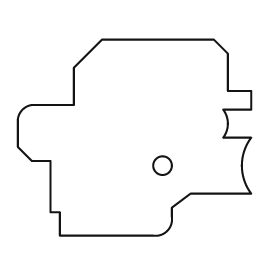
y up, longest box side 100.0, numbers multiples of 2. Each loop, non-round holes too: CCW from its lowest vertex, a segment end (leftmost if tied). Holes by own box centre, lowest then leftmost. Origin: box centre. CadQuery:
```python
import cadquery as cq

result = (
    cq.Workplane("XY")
    .moveTo(-32.0, -42.0)
    .lineTo(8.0, -42.0)
    .threePointArc((14.0, -40.0), (16.0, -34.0))
    .lineTo(16.0, -30.0)
    .lineTo(24.0, -24.0)
    .lineTo(50.0, -24.0)
    .threePointArc((46.0, -12.0), (50.0, 0.0))
    .lineTo(38.0, 0.0)
    .threePointArc((40.0, 6.0), (38.0, 12.0))
    .lineTo(50.0, 12.0)
    .lineTo(50.0, 20.0)
    .lineTo(40.0, 20.0)
    .lineTo(40.0, 36.0)
    .lineTo(34.0, 42.0)
    .lineTo(-14.0, 42.0)
    .lineTo(-26.0, 30.0)
    .lineTo(-26.0, 14.0)
    .lineTo(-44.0, 14.0)
    .threePointArc((-48.0, 12.0), (-50.0, 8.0))
    .lineTo(-50.0, -4.0)
    .lineTo(-44.0, -10.0)
    .lineTo(-36.0, -10.0)
    .lineTo(-36.0, -32.0)
    .lineTo(-32.0, -32.0)
    .close()
    .moveTo(12.0, -12.0)
    .circle(4.0)
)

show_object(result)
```